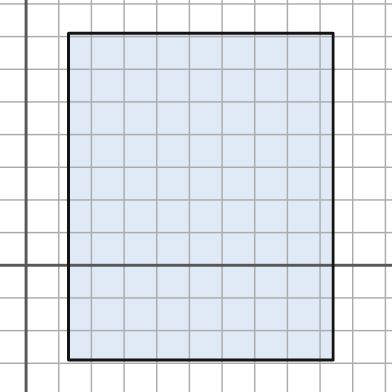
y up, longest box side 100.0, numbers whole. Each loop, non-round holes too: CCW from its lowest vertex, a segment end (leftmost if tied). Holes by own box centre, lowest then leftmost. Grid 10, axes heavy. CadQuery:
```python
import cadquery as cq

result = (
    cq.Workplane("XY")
    .moveTo(13.0, -29.0)
    .lineTo(94.0, -29.0)
    .lineTo(94.0, 71.0)
    .lineTo(13.0, 71.0)
    .close()
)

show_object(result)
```